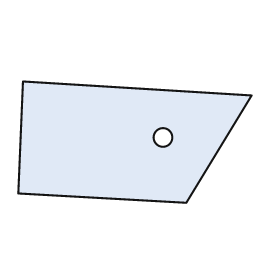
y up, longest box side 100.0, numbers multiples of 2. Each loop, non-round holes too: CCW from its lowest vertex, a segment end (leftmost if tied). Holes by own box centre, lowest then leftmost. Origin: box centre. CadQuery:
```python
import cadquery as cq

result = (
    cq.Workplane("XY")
    .moveTo(22.0, -26.0)
    .lineTo(50.0, 20.0)
    .lineTo(-48.0, 26.0)
    .lineTo(-50.0, -22.0)
    .close()
    .moveTo(12.0, 2.0)
    .circle(4.0)
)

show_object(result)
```